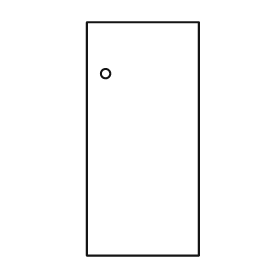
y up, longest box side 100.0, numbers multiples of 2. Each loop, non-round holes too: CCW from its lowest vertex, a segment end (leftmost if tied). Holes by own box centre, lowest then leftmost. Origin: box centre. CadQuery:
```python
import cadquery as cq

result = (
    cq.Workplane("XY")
    .moveTo(-24.0, -50.0)
    .lineTo(24.0, -50.0)
    .lineTo(24.0, 50.0)
    .lineTo(-24.0, 50.0)
    .close()
    .moveTo(-16.0, 28.0)
    .circle(2.0)
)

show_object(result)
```